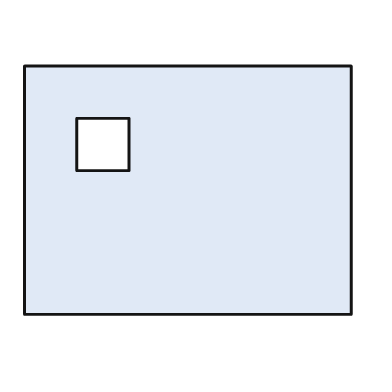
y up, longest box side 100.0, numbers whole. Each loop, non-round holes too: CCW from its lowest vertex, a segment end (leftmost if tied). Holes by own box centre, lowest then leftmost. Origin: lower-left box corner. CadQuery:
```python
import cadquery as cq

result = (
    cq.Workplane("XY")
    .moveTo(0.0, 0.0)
    .lineTo(100.0, 0.0)
    .lineTo(100.0, 76.0)
    .lineTo(0.0, 76.0)
    .close()
    .moveTo(16.0, 44.0)
    .lineTo(32.0, 44.0)
    .lineTo(32.0, 60.0)
    .lineTo(16.0, 60.0)
    .close()
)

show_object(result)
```